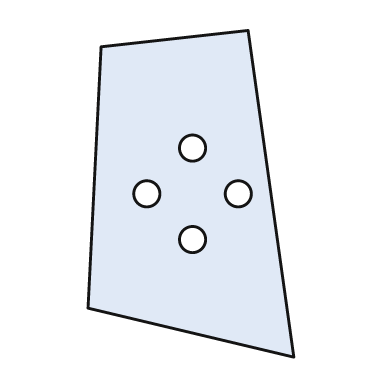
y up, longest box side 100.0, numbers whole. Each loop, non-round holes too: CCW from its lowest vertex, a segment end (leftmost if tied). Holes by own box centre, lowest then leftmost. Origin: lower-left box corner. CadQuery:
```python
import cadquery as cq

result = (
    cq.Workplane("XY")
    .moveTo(63.0, 0.0)
    .lineTo(49.0, 100.0)
    .lineTo(4.0, 95.0)
    .lineTo(0.0, 15.0)
    .close()
    .moveTo(32.0, 36.0)
    .circle(4.0)
    .moveTo(18.0, 50.0)
    .circle(4.0)
    .moveTo(46.0, 50.0)
    .circle(4.0)
    .moveTo(32.0, 64.0)
    .circle(4.0)
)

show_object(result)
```